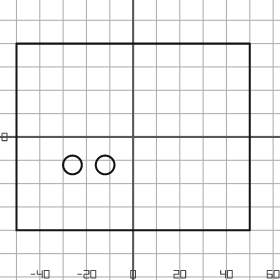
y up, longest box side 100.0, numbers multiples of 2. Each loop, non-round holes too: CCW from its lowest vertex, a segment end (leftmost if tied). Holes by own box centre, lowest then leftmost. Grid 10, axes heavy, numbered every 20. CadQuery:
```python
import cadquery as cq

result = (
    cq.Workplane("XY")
    .moveTo(-50.0, -40.0)
    .lineTo(50.0, -40.0)
    .lineTo(50.0, 40.0)
    .lineTo(-50.0, 40.0)
    .close()
    .moveTo(-26.0, -12.0)
    .circle(4.0)
    .moveTo(-12.0, -12.0)
    .circle(4.0)
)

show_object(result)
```